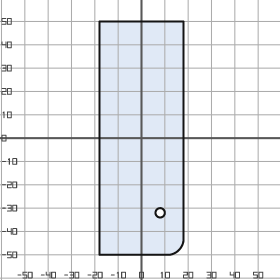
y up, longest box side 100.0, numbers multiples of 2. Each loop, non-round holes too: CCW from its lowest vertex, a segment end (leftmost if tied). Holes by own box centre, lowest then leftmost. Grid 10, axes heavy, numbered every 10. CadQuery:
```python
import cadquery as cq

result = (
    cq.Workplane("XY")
    .moveTo(-18.0, -50.0)
    .lineTo(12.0, -50.0)
    .threePointArc((16.0, -48.0), (18.0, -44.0))
    .lineTo(18.0, 50.0)
    .lineTo(-18.0, 50.0)
    .close()
    .moveTo(8.0, -32.0)
    .circle(2.0)
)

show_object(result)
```